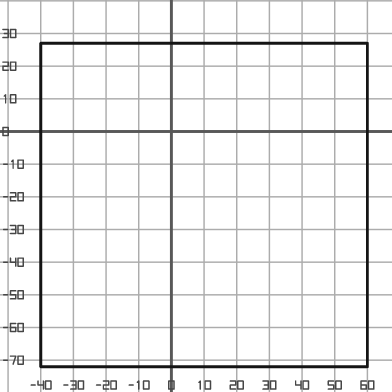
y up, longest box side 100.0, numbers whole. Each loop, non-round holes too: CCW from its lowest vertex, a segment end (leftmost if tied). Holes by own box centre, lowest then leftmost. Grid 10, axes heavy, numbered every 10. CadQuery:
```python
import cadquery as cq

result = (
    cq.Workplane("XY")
    .moveTo(-40.0, -72.0)
    .lineTo(60.0, -72.0)
    .lineTo(60.0, 27.0)
    .lineTo(-40.0, 27.0)
    .close()
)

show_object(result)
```